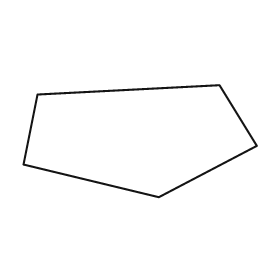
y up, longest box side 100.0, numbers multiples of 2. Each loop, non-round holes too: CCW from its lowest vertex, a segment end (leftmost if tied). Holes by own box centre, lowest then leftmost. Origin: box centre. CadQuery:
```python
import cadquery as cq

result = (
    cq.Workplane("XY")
    .moveTo(8.0, -24.0)
    .lineTo(50.0, -2.0)
    .lineTo(34.0, 24.0)
    .lineTo(-44.0, 20.0)
    .lineTo(-50.0, -10.0)
    .close()
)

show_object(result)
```